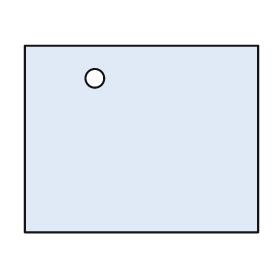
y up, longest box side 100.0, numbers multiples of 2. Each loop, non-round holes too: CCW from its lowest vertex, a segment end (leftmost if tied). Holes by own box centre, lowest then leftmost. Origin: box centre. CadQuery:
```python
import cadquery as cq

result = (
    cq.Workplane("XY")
    .moveTo(-50.0, -40.0)
    .lineTo(50.0, -40.0)
    .lineTo(50.0, 40.0)
    .lineTo(-50.0, 40.0)
    .close()
    .moveTo(-20.0, 26.0)
    .circle(4.0)
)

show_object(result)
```